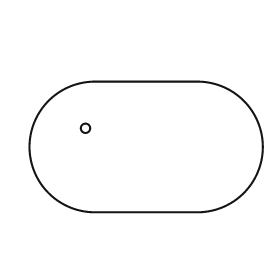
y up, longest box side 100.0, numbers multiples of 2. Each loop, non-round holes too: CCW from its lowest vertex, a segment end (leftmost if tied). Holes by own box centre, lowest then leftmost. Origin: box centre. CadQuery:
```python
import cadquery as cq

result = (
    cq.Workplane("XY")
    .moveTo(-22.0, -28.0)
    .lineTo(22.0, -28.0)
    .threePointArc((50.0, 0.0), (22.0, 28.0))
    .lineTo(-22.0, 28.0)
    .threePointArc((-50.0, 0.0), (-22.0, -28.0))
    .close()
    .moveTo(-26.0, 8.0)
    .circle(2.0)
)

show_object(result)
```